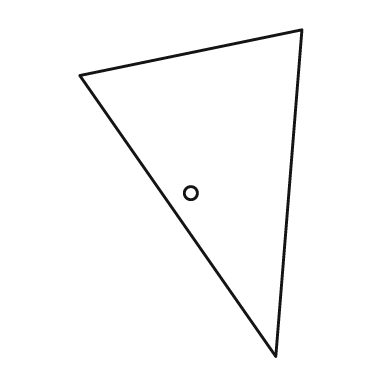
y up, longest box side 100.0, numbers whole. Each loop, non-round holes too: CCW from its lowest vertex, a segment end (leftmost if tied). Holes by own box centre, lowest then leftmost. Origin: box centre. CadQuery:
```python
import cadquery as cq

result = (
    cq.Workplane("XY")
    .moveTo(26.0, -50.0)
    .lineTo(34.0, 50.0)
    .lineTo(-34.0, 36.0)
    .close()
    .moveTo(0.0, 0.0)
    .circle(2.0)
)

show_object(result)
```